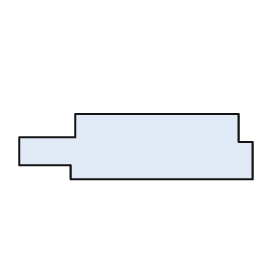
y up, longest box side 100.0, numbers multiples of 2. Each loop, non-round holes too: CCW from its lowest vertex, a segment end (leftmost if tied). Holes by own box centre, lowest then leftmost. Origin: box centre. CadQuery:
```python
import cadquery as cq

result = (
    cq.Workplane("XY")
    .moveTo(-28.0, -14.0)
    .lineTo(50.0, -14.0)
    .lineTo(50.0, 2.0)
    .lineTo(44.0, 2.0)
    .lineTo(44.0, 14.0)
    .lineTo(-26.0, 14.0)
    .lineTo(-26.0, 4.0)
    .lineTo(-50.0, 4.0)
    .lineTo(-50.0, -8.0)
    .lineTo(-28.0, -8.0)
    .close()
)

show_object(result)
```